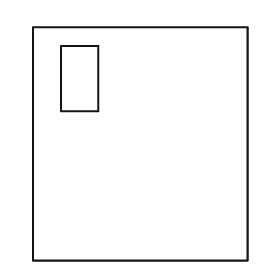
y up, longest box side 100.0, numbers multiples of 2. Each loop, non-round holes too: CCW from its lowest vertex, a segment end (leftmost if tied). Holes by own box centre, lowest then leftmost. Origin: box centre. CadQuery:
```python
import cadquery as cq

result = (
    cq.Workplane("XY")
    .moveTo(-46.0, -50.0)
    .lineTo(46.0, -50.0)
    .lineTo(46.0, 50.0)
    .lineTo(-46.0, 50.0)
    .close()
    .moveTo(-34.0, 14.0)
    .lineTo(-18.0, 14.0)
    .lineTo(-18.0, 42.0)
    .lineTo(-34.0, 42.0)
    .close()
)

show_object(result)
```